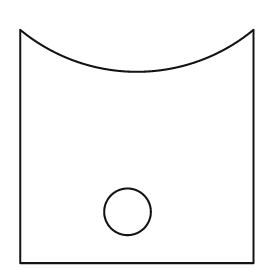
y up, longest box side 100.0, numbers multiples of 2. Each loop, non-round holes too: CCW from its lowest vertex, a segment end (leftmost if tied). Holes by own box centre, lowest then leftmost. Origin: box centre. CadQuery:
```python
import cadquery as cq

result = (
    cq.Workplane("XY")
    .moveTo(-50.0, -50.0)
    .lineTo(50.0, -50.0)
    .lineTo(50.0, 50.0)
    .threePointArc((0.0, 32.0), (-50.0, 50.0))
    .close()
    .moveTo(-4.0, -28.0)
    .circle(10.0)
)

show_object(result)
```